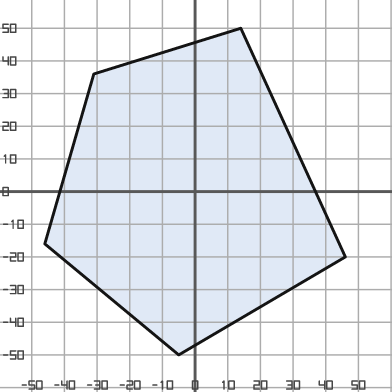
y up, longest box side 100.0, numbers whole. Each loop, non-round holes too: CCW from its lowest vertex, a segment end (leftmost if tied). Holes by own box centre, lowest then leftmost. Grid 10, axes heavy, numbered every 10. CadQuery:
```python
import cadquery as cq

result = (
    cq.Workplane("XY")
    .moveTo(-5.0, -50.0)
    .lineTo(46.0, -20.0)
    .lineTo(14.0, 50.0)
    .lineTo(-31.0, 36.0)
    .lineTo(-46.0, -16.0)
    .close()
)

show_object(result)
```